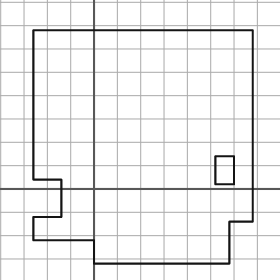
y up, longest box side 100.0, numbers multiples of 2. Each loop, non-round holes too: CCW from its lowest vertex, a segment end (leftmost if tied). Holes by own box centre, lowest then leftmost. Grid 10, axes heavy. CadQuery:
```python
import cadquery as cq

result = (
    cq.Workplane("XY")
    .moveTo(0.0, -32.0)
    .lineTo(58.0, -32.0)
    .lineTo(58.0, -14.0)
    .lineTo(68.0, -14.0)
    .lineTo(68.0, 68.0)
    .lineTo(-26.0, 68.0)
    .lineTo(-26.0, 4.0)
    .lineTo(-14.0, 4.0)
    .lineTo(-14.0, -12.0)
    .lineTo(-26.0, -12.0)
    .lineTo(-26.0, -22.0)
    .lineTo(0.0, -22.0)
    .close()
    .moveTo(52.0, 2.0)
    .lineTo(60.0, 2.0)
    .lineTo(60.0, 14.0)
    .lineTo(52.0, 14.0)
    .close()
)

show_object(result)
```